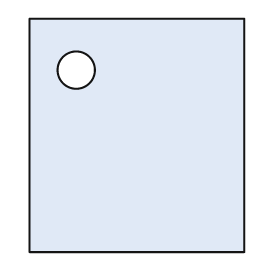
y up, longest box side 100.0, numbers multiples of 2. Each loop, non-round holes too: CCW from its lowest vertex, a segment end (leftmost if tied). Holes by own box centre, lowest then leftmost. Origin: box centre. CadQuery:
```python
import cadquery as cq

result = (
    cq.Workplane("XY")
    .moveTo(-46.0, -50.0)
    .lineTo(46.0, -50.0)
    .lineTo(46.0, 50.0)
    .lineTo(-46.0, 50.0)
    .close()
    .moveTo(-26.0, 28.0)
    .circle(8.0)
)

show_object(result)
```